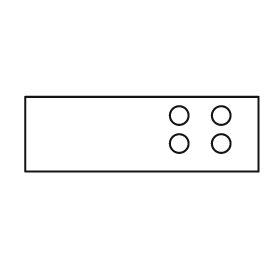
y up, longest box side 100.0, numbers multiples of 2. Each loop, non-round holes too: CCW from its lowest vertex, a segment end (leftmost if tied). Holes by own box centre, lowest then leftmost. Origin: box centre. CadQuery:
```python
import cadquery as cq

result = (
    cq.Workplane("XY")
    .moveTo(-50.0, -16.0)
    .lineTo(50.0, -16.0)
    .lineTo(50.0, 16.0)
    .lineTo(-50.0, 16.0)
    .close()
    .moveTo(16.0, -4.0)
    .circle(4.0)
    .moveTo(34.0, -4.0)
    .circle(4.0)
    .moveTo(16.0, 8.0)
    .circle(4.0)
    .moveTo(34.0, 8.0)
    .circle(4.0)
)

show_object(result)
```